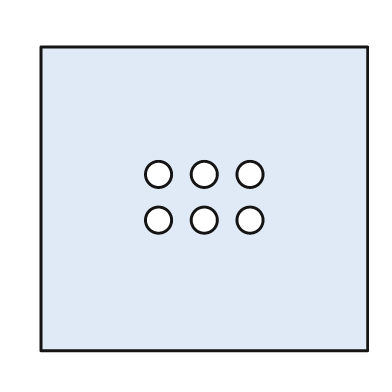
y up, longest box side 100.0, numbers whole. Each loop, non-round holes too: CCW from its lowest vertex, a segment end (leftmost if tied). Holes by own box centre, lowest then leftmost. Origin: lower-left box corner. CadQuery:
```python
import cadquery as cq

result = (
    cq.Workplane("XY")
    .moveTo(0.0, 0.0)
    .lineTo(100.0, 0.0)
    .lineTo(100.0, 93.0)
    .lineTo(0.0, 93.0)
    .close()
    .moveTo(36.0, 40.0)
    .circle(4.0)
    .moveTo(50.0, 40.0)
    .circle(4.0)
    .moveTo(64.0, 40.0)
    .circle(4.0)
    .moveTo(36.0, 54.0)
    .circle(4.0)
    .moveTo(50.0, 54.0)
    .circle(4.0)
    .moveTo(64.0, 54.0)
    .circle(4.0)
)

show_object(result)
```